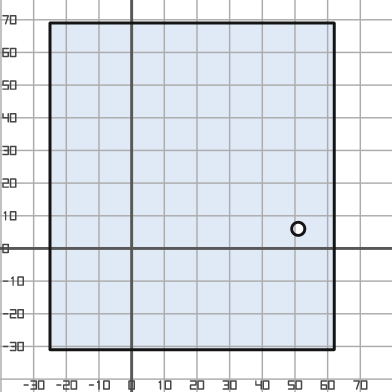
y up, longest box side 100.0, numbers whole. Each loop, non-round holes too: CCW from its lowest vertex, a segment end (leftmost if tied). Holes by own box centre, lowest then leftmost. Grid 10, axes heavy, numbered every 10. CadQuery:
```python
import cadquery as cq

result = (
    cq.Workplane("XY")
    .moveTo(-25.0, -31.0)
    .lineTo(62.0, -31.0)
    .lineTo(62.0, 69.0)
    .lineTo(-25.0, 69.0)
    .close()
    .moveTo(51.0, 6.0)
    .circle(2.0)
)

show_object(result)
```